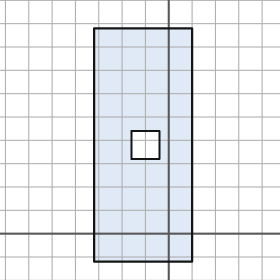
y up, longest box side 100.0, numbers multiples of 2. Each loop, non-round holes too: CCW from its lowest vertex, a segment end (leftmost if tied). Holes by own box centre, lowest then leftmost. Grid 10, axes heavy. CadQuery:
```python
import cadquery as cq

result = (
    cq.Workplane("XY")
    .moveTo(-32.0, -12.0)
    .lineTo(10.0, -12.0)
    .lineTo(10.0, 88.0)
    .lineTo(-32.0, 88.0)
    .close()
    .moveTo(-16.0, 32.0)
    .lineTo(-4.0, 32.0)
    .lineTo(-4.0, 44.0)
    .lineTo(-16.0, 44.0)
    .close()
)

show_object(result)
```